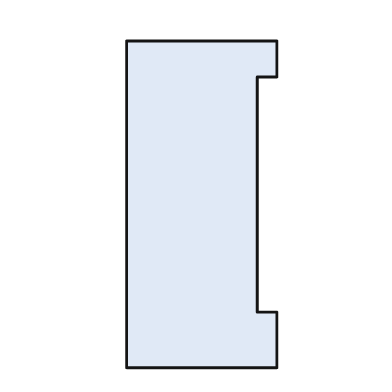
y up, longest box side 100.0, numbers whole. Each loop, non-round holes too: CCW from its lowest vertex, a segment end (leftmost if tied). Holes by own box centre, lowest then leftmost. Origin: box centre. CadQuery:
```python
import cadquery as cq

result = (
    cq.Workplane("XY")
    .moveTo(-23.0, -50.0)
    .lineTo(23.0, -50.0)
    .lineTo(23.0, -33.0)
    .lineTo(17.0, -33.0)
    .lineTo(17.0, 39.0)
    .lineTo(23.0, 39.0)
    .lineTo(23.0, 50.0)
    .lineTo(-23.0, 50.0)
    .close()
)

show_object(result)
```